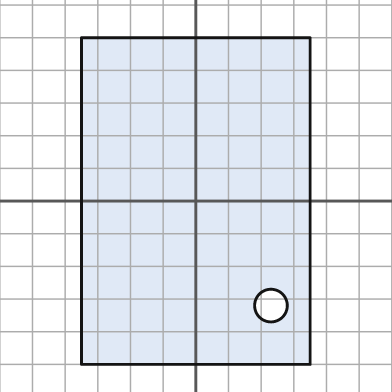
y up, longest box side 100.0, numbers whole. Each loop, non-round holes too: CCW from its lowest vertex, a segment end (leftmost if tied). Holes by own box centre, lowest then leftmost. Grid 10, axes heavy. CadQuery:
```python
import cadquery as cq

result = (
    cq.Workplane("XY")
    .moveTo(-35.0, -50.0)
    .lineTo(35.0, -50.0)
    .lineTo(35.0, 50.0)
    .lineTo(-35.0, 50.0)
    .close()
    .moveTo(23.0, -32.0)
    .circle(5.0)
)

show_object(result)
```